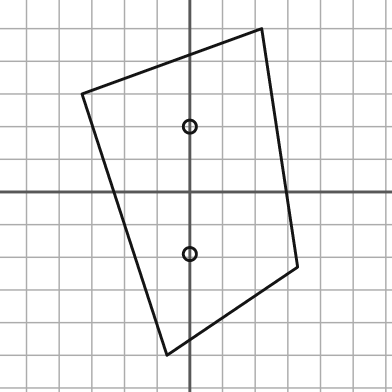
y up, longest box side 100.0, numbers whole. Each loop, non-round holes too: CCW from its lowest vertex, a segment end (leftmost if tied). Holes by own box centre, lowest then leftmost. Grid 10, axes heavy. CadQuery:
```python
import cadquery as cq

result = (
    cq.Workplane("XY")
    .moveTo(-7.0, -50.0)
    .lineTo(33.0, -23.0)
    .lineTo(22.0, 50.0)
    .lineTo(-33.0, 30.0)
    .close()
    .moveTo(0.0, -19.0)
    .circle(2.0)
    .moveTo(0.0, 20.0)
    .circle(2.0)
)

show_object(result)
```